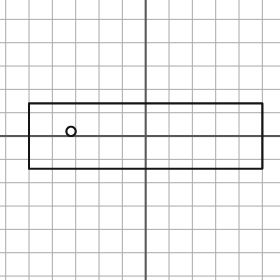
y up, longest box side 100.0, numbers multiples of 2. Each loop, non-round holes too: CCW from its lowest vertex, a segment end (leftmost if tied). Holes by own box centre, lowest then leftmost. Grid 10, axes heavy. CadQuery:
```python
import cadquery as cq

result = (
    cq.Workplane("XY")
    .moveTo(-50.0, -14.0)
    .lineTo(50.0, -14.0)
    .lineTo(50.0, 14.0)
    .lineTo(-50.0, 14.0)
    .close()
    .moveTo(-32.0, 2.0)
    .circle(2.0)
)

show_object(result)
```